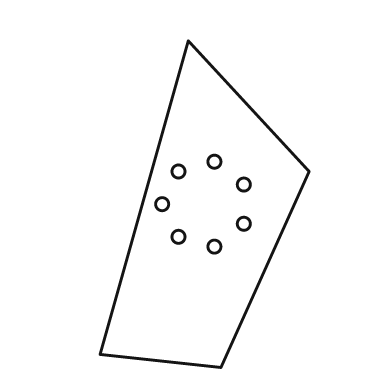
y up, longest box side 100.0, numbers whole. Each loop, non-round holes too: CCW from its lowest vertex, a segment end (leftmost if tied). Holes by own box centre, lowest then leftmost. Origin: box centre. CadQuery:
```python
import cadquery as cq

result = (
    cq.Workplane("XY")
    .moveTo(5.0, -50.0)
    .lineTo(32.0, 10.0)
    .lineTo(-5.0, 50.0)
    .lineTo(-32.0, -46.0)
    .close()
    .moveTo(3.0, -13.0)
    .circle(2.0)
    .moveTo(-8.0, -10.0)
    .circle(2.0)
    .moveTo(12.0, -6.0)
    .circle(2.0)
    .moveTo(-13.0, 0.0)
    .circle(2.0)
    .moveTo(12.0, 6.0)
    .circle(2.0)
    .moveTo(-8.0, 10.0)
    .circle(2.0)
    .moveTo(3.0, 13.0)
    .circle(2.0)
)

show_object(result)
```